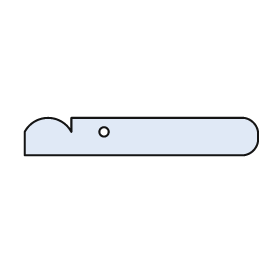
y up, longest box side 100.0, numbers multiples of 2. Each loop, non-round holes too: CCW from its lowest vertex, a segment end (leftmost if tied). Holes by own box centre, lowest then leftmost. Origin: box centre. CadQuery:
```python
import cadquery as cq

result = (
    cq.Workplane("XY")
    .moveTo(-50.0, -8.0)
    .lineTo(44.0, -8.0)
    .threePointArc((48.0, -6.0), (50.0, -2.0))
    .lineTo(50.0, 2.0)
    .threePointArc((48.0, 6.0), (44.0, 8.0))
    .lineTo(-30.0, 8.0)
    .lineTo(-30.0, 2.0)
    .threePointArc((-40.0, 8.0), (-50.0, 2.0))
    .close()
    .moveTo(-16.0, 2.0)
    .circle(2.0)
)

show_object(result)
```